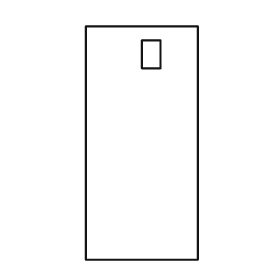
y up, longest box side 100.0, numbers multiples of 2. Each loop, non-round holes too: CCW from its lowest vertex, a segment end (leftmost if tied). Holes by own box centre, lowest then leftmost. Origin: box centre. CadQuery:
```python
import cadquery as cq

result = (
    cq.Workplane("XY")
    .moveTo(-24.0, -50.0)
    .lineTo(24.0, -50.0)
    .lineTo(24.0, 50.0)
    .lineTo(-24.0, 50.0)
    .close()
    .moveTo(0.0, 32.0)
    .lineTo(8.0, 32.0)
    .lineTo(8.0, 44.0)
    .lineTo(0.0, 44.0)
    .close()
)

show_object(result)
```